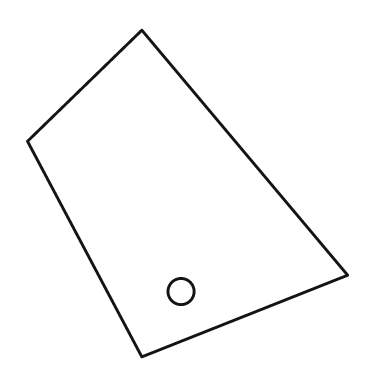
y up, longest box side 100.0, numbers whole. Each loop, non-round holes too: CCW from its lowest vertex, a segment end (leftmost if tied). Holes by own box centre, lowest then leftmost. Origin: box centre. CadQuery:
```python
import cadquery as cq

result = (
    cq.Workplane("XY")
    .moveTo(-14.0, -50.0)
    .lineTo(49.0, -25.0)
    .lineTo(-14.0, 50.0)
    .lineTo(-49.0, 16.0)
    .close()
    .moveTo(-2.0, -30.0)
    .circle(4.0)
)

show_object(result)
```